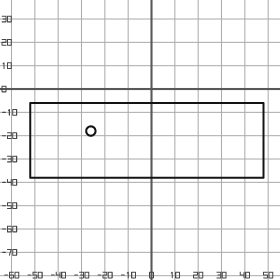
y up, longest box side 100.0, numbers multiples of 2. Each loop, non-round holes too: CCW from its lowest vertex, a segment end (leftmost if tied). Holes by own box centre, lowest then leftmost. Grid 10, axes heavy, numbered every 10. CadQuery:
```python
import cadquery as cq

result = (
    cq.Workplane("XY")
    .moveTo(-52.0, -38.0)
    .lineTo(48.0, -38.0)
    .lineTo(48.0, -6.0)
    .lineTo(-52.0, -6.0)
    .close()
    .moveTo(-26.0, -18.0)
    .circle(2.0)
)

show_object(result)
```